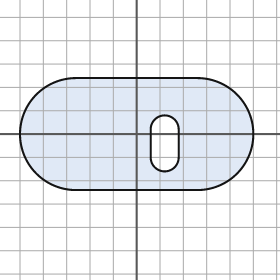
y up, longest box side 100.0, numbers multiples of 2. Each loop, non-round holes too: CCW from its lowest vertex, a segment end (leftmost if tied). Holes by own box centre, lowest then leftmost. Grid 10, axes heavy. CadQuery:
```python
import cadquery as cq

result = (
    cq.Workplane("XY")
    .moveTo(-26.0, -24.0)
    .lineTo(26.0, -24.0)
    .threePointArc((50.0, 0.0), (26.0, 24.0))
    .lineTo(-26.0, 24.0)
    .threePointArc((-50.0, 0.0), (-26.0, -24.0))
    .close()
    .moveTo(6.0, -10.0)
    .threePointArc((12.0, -16.0), (18.0, -10.0))
    .lineTo(18.0, 2.0)
    .threePointArc((12.0, 8.0), (6.0, 2.0))
    .close()
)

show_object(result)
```